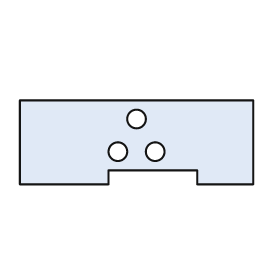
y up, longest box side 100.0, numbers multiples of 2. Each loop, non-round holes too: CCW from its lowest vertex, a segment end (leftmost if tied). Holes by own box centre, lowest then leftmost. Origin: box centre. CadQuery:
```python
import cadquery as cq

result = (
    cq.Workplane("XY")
    .moveTo(-50.0, -18.0)
    .lineTo(-12.0, -18.0)
    .lineTo(-12.0, -12.0)
    .lineTo(26.0, -12.0)
    .lineTo(26.0, -18.0)
    .lineTo(50.0, -18.0)
    .lineTo(50.0, 18.0)
    .lineTo(-50.0, 18.0)
    .close()
    .moveTo(-8.0, -4.0)
    .circle(4.0)
    .moveTo(8.0, -4.0)
    .circle(4.0)
    .moveTo(0.0, 10.0)
    .circle(4.0)
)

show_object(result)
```